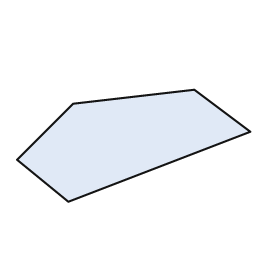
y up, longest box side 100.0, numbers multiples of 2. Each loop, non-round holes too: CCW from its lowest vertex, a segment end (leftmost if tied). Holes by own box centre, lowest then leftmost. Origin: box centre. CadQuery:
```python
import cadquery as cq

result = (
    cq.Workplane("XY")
    .moveTo(-28.0, -24.0)
    .lineTo(50.0, 6.0)
    .lineTo(26.0, 24.0)
    .lineTo(-26.0, 18.0)
    .lineTo(-50.0, -6.0)
    .close()
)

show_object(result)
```